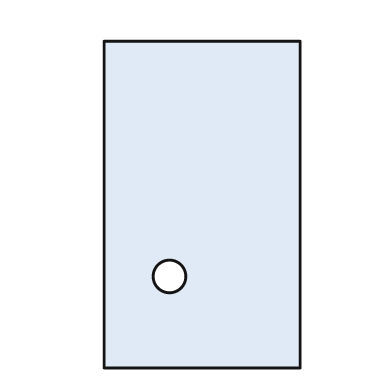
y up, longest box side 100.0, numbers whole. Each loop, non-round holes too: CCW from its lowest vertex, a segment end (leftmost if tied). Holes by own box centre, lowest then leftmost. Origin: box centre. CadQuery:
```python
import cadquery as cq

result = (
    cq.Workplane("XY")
    .moveTo(-30.0, -50.0)
    .lineTo(30.0, -50.0)
    .lineTo(30.0, 50.0)
    .lineTo(-30.0, 50.0)
    .close()
    .moveTo(-10.0, -22.0)
    .circle(5.0)
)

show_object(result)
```